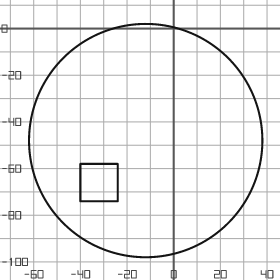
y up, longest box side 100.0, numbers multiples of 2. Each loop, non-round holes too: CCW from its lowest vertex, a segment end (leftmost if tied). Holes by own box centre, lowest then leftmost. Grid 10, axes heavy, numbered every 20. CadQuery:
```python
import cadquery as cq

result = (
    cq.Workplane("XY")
    .moveTo(-12.0, -48.0)
    .circle(50.0)
    .moveTo(-40.0, -74.0)
    .lineTo(-24.0, -74.0)
    .lineTo(-24.0, -58.0)
    .lineTo(-40.0, -58.0)
    .close()
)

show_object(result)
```